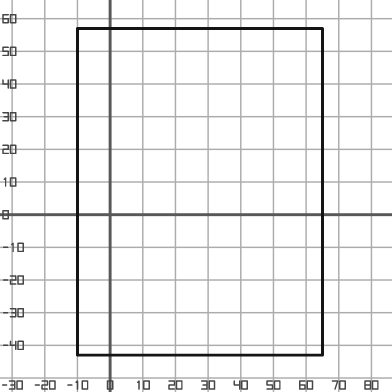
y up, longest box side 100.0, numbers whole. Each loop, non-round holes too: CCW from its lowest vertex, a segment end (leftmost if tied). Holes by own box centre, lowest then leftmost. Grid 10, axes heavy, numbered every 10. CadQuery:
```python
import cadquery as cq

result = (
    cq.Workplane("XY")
    .moveTo(-10.0, -43.0)
    .lineTo(65.0, -43.0)
    .lineTo(65.0, 57.0)
    .lineTo(-10.0, 57.0)
    .close()
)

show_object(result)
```